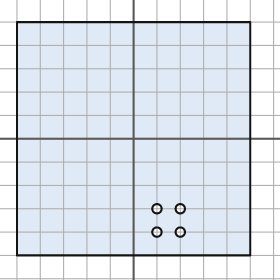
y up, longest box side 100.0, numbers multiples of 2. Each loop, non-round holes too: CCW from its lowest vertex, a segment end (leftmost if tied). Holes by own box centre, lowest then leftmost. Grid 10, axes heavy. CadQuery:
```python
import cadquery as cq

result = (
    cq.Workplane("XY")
    .moveTo(-50.0, -50.0)
    .lineTo(50.0, -50.0)
    .lineTo(50.0, 50.0)
    .lineTo(-50.0, 50.0)
    .close()
    .moveTo(10.0, -40.0)
    .circle(2.0)
    .moveTo(20.0, -40.0)
    .circle(2.0)
    .moveTo(10.0, -30.0)
    .circle(2.0)
    .moveTo(20.0, -30.0)
    .circle(2.0)
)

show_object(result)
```